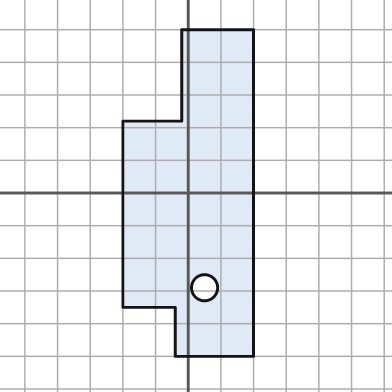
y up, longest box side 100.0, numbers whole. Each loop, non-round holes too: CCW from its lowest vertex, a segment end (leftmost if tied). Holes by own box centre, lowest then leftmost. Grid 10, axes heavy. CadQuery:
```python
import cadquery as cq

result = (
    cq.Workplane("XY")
    .moveTo(-4.0, -50.0)
    .lineTo(20.0, -50.0)
    .lineTo(20.0, 50.0)
    .lineTo(-2.0, 50.0)
    .lineTo(-2.0, 22.0)
    .lineTo(-20.0, 22.0)
    .lineTo(-20.0, -35.0)
    .lineTo(-4.0, -35.0)
    .close()
    .moveTo(5.0, -29.0)
    .circle(4.0)
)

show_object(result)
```